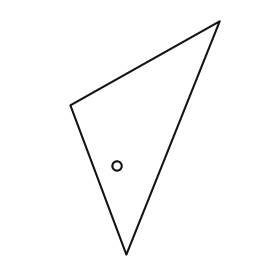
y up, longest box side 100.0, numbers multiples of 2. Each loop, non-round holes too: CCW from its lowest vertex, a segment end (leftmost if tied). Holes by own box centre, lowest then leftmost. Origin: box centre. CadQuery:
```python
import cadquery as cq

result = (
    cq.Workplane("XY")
    .moveTo(-8.0, -50.0)
    .lineTo(32.0, 50.0)
    .lineTo(-32.0, 14.0)
    .close()
    .moveTo(-12.0, -12.0)
    .circle(2.0)
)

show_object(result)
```